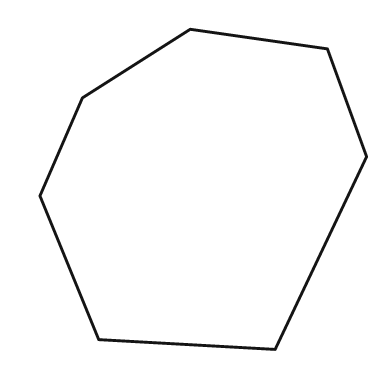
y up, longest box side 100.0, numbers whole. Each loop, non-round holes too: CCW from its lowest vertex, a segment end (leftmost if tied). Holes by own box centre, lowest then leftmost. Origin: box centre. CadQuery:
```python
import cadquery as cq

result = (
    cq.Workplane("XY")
    .moveTo(22.0, -49.0)
    .lineTo(50.0, 10.0)
    .lineTo(38.0, 43.0)
    .lineTo(-4.0, 49.0)
    .lineTo(-37.0, 28.0)
    .lineTo(-50.0, -2.0)
    .lineTo(-32.0, -46.0)
    .close()
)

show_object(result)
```